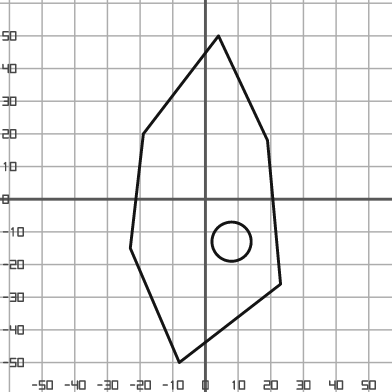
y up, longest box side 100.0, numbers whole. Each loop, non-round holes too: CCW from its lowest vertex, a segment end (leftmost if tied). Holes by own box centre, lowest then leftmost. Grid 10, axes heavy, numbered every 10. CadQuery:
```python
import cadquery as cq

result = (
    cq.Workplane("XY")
    .moveTo(-8.0, -50.0)
    .lineTo(23.0, -26.0)
    .lineTo(19.0, 18.0)
    .lineTo(4.0, 50.0)
    .lineTo(-19.0, 20.0)
    .lineTo(-23.0, -15.0)
    .close()
    .moveTo(8.0, -13.0)
    .circle(6.0)
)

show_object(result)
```